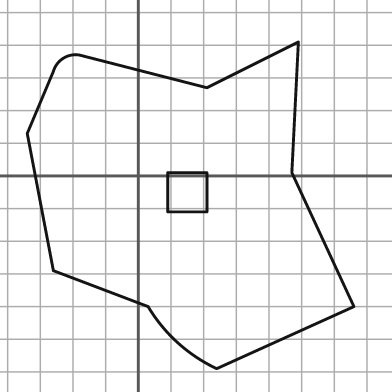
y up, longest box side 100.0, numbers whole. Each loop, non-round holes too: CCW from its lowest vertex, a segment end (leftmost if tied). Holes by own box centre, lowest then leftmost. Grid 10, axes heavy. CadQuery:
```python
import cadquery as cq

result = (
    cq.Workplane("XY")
    .moveTo(24.0, -59.0)
    .lineTo(66.0, -40.0)
    .lineTo(47.0, 1.0)
    .lineTo(49.0, 41.0)
    .lineTo(21.0, 27.0)
    .lineTo(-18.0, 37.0)
    .threePointArc((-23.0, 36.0), (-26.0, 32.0))
    .lineTo(-34.0, 13.0)
    .lineTo(-26.0, -29.0)
    .lineTo(3.0, -40.0)
    .threePointArc((12.0, -51.0), (24.0, -59.0))
    .close()
    .moveTo(9.0, -11.0)
    .lineTo(21.0, -11.0)
    .lineTo(21.0, 1.0)
    .lineTo(9.0, 1.0)
    .close()
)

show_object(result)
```